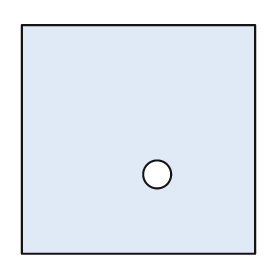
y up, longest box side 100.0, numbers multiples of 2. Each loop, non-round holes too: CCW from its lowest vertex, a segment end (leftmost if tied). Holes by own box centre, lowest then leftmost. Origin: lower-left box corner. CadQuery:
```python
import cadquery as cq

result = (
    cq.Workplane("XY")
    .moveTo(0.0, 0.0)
    .lineTo(100.0, 0.0)
    .lineTo(100.0, 98.0)
    .lineTo(0.0, 98.0)
    .close()
    .moveTo(58.0, 34.0)
    .circle(6.0)
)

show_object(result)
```